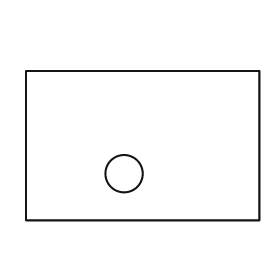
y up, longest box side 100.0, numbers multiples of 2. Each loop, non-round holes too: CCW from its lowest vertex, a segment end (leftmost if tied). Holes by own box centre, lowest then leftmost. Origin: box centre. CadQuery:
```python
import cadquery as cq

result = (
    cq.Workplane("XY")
    .moveTo(-50.0, -32.0)
    .lineTo(50.0, -32.0)
    .lineTo(50.0, 32.0)
    .lineTo(-50.0, 32.0)
    .close()
    .moveTo(-8.0, -12.0)
    .circle(8.0)
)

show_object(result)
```